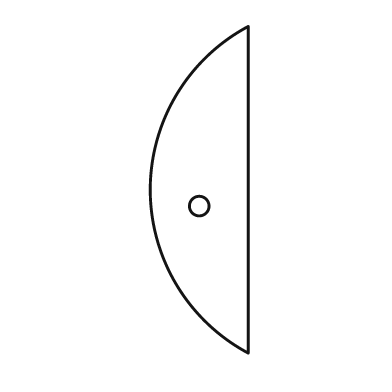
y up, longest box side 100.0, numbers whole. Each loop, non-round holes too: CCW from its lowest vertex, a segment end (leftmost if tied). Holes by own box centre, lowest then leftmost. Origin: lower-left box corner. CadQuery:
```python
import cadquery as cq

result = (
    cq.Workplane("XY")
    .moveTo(30.0, 0.0)
    .lineTo(30.0, 100.0)
    .threePointArc((0.0, 50.0), (30.0, 0.0))
    .close()
    .moveTo(15.0, 45.0)
    .circle(3.0)
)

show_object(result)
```